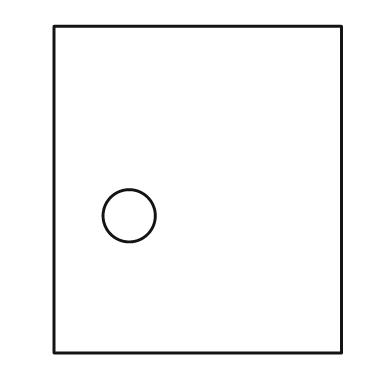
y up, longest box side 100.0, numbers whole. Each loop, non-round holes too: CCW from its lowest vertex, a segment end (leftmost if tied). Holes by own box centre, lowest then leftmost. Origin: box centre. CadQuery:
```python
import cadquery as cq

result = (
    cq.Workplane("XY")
    .moveTo(-44.0, -50.0)
    .lineTo(44.0, -50.0)
    .lineTo(44.0, 50.0)
    .lineTo(-44.0, 50.0)
    .close()
    .moveTo(-21.0, -8.0)
    .circle(8.0)
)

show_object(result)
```